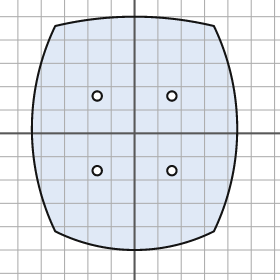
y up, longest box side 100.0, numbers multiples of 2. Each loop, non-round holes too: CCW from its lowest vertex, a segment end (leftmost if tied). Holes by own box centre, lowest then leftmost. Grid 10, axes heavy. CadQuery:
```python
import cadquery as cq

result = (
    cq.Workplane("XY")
    .moveTo(-34.0, -42.0)
    .threePointArc((0.0, -50.0), (34.0, -42.0))
    .threePointArc((44.0, 2.0), (34.0, 46.0))
    .threePointArc((0.0, 50.0), (-34.0, 46.0))
    .threePointArc((-44.0, 2.0), (-34.0, -42.0))
    .close()
    .moveTo(-16.0, -16.0)
    .circle(2.0)
    .moveTo(16.0, -16.0)
    .circle(2.0)
    .moveTo(-16.0, 16.0)
    .circle(2.0)
    .moveTo(16.0, 16.0)
    .circle(2.0)
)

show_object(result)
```